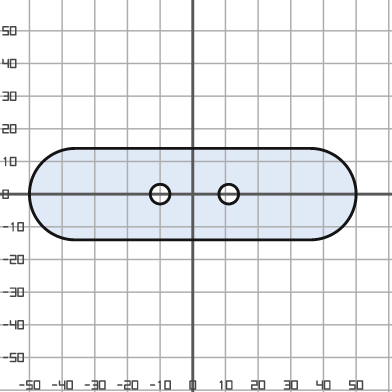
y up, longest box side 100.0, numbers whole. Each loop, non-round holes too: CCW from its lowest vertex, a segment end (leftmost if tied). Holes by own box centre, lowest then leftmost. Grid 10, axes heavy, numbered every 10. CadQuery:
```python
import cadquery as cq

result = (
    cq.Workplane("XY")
    .moveTo(-36.0, -14.0)
    .lineTo(36.0, -14.0)
    .threePointArc((50.0, 0.0), (36.0, 14.0))
    .lineTo(-36.0, 14.0)
    .threePointArc((-50.0, 0.0), (-36.0, -14.0))
    .close()
    .moveTo(-10.0, 0.0)
    .circle(3.0)
    .moveTo(11.0, 0.0)
    .circle(3.0)
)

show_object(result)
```